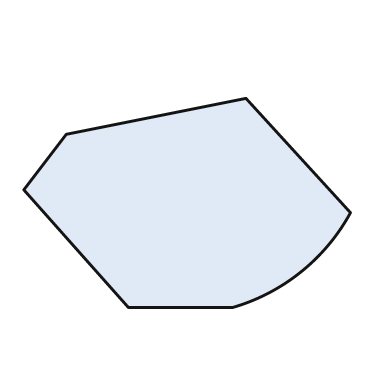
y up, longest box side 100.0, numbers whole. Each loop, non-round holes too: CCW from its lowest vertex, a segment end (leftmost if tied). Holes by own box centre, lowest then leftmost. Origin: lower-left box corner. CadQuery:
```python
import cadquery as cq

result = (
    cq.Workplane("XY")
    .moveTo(32.0, 0.0)
    .lineTo(64.0, 0.0)
    .threePointArc((85.0, 11.0), (100.0, 29.0))
    .lineTo(68.0, 64.0)
    .lineTo(13.0, 53.0)
    .lineTo(0.0, 36.0)
    .close()
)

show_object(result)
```